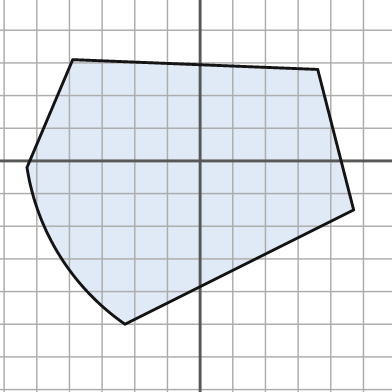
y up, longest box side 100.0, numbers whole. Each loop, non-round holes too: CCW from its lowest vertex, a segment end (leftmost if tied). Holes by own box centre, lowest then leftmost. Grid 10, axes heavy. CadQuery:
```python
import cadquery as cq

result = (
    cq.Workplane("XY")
    .moveTo(-23.0, -50.0)
    .lineTo(47.0, -15.0)
    .lineTo(36.0, 28.0)
    .lineTo(-39.0, 31.0)
    .lineTo(-53.0, -2.0)
    .threePointArc((-43.0, -29.0), (-23.0, -50.0))
    .close()
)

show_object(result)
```